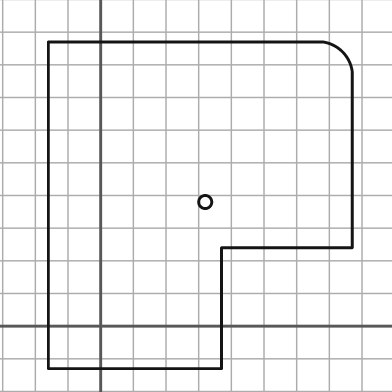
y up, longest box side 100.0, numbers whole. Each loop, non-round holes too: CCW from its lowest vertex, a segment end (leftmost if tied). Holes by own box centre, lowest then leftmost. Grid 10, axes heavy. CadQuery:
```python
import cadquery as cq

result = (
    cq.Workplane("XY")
    .moveTo(-16.0, -13.0)
    .lineTo(37.0, -13.0)
    .lineTo(37.0, 24.0)
    .lineTo(77.0, 24.0)
    .lineTo(77.0, 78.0)
    .threePointArc((74.0, 84.0), (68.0, 87.0))
    .lineTo(-16.0, 87.0)
    .close()
    .moveTo(32.0, 38.0)
    .circle(2.0)
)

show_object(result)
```